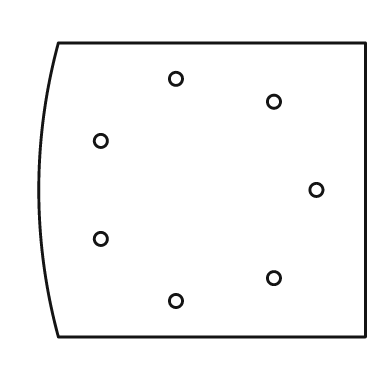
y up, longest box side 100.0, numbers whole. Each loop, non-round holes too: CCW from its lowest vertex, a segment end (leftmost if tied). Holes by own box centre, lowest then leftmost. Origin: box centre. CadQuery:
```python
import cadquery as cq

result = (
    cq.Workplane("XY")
    .moveTo(-44.0, -45.0)
    .lineTo(50.0, -45.0)
    .lineTo(50.0, 45.0)
    .lineTo(-44.0, 45.0)
    .threePointArc((-50.0, 0.0), (-44.0, -45.0))
    .close()
    .moveTo(-8.0, -34.0)
    .circle(2.0)
    .moveTo(22.0, -27.0)
    .circle(2.0)
    .moveTo(-31.0, -15.0)
    .circle(2.0)
    .moveTo(35.0, 0.0)
    .circle(2.0)
    .moveTo(-31.0, 15.0)
    .circle(2.0)
    .moveTo(22.0, 27.0)
    .circle(2.0)
    .moveTo(-8.0, 34.0)
    .circle(2.0)
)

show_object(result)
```